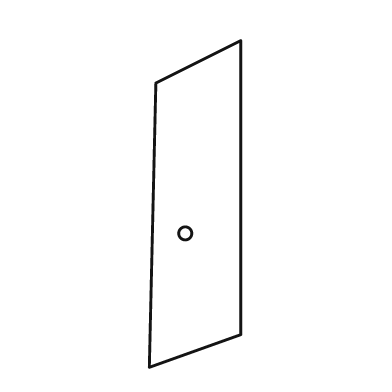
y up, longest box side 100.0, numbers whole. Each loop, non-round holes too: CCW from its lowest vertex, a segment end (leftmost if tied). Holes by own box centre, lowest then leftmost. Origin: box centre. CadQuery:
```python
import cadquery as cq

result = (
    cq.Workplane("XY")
    .moveTo(-14.0, -50.0)
    .lineTo(14.0, -40.0)
    .lineTo(14.0, 50.0)
    .lineTo(-12.0, 37.0)
    .close()
    .moveTo(-3.0, -9.0)
    .circle(2.0)
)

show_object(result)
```